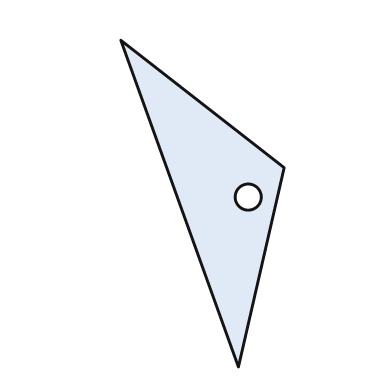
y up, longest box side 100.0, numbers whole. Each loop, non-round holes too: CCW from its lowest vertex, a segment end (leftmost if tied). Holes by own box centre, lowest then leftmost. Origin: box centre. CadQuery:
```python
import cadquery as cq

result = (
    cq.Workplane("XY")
    .moveTo(11.0, -50.0)
    .lineTo(25.0, 11.0)
    .lineTo(-25.0, 50.0)
    .close()
    .moveTo(14.0, 2.0)
    .circle(4.0)
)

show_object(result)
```